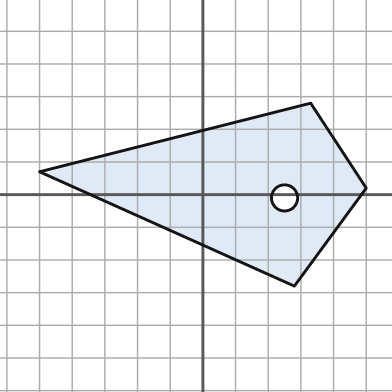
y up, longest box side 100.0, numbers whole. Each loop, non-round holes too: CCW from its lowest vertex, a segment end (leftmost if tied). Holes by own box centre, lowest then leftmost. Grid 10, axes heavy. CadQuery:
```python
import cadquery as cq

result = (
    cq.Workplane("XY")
    .moveTo(28.0, -28.0)
    .lineTo(50.0, 2.0)
    .lineTo(33.0, 28.0)
    .lineTo(-50.0, 7.0)
    .close()
    .moveTo(25.0, -1.0)
    .circle(4.0)
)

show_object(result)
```